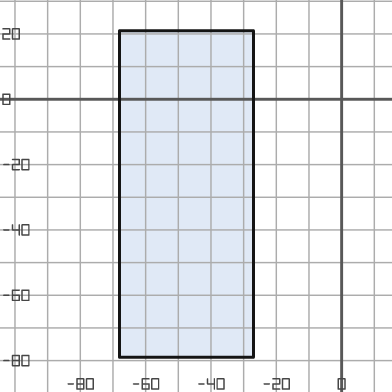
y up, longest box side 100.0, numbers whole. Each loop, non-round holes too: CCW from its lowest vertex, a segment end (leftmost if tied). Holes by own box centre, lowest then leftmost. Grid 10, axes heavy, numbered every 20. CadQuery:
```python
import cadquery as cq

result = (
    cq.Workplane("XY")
    .moveTo(-68.0, -79.0)
    .lineTo(-27.0, -79.0)
    .lineTo(-27.0, 21.0)
    .lineTo(-68.0, 21.0)
    .close()
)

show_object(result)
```